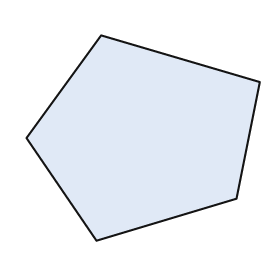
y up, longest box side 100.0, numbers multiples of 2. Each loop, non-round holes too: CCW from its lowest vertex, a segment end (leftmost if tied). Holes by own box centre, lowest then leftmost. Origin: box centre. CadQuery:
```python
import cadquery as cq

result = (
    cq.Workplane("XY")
    .moveTo(-20.0, -44.0)
    .lineTo(40.0, -26.0)
    .lineTo(50.0, 24.0)
    .lineTo(-18.0, 44.0)
    .lineTo(-50.0, 0.0)
    .close()
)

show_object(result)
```